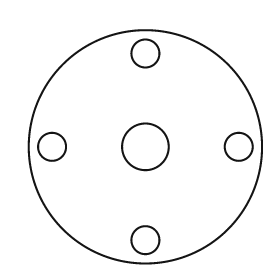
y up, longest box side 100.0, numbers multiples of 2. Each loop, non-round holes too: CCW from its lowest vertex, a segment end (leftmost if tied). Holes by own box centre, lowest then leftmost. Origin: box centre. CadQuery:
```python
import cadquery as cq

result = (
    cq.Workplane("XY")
    .moveTo(0.0, 0.0)
    .circle(50.0)
    .moveTo(0.0, -40.0)
    .circle(6.0)
    .moveTo(-40.0, 0.0)
    .circle(6.0)
    .moveTo(0.0, 0.0)
    .circle(10.0)
    .moveTo(40.0, 0.0)
    .circle(6.0)
    .moveTo(0.0, 40.0)
    .circle(6.0)
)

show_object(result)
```